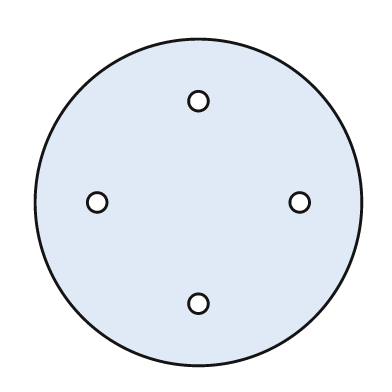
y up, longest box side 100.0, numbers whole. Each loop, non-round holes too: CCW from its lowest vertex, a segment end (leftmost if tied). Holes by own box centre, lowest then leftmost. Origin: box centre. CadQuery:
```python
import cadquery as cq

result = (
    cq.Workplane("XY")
    .moveTo(0.0, 0.0)
    .circle(50.0)
    .moveTo(0.0, -31.0)
    .circle(3.0)
    .moveTo(-31.0, 0.0)
    .circle(3.0)
    .moveTo(31.0, 0.0)
    .circle(3.0)
    .moveTo(0.0, 31.0)
    .circle(3.0)
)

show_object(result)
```